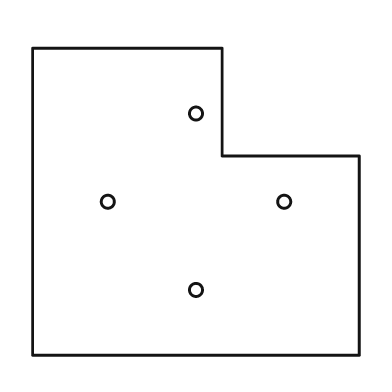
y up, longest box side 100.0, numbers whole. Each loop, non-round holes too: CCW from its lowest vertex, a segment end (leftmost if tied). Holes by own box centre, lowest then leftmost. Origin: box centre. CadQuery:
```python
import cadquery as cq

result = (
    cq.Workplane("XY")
    .moveTo(-50.0, -47.0)
    .lineTo(50.0, -47.0)
    .lineTo(50.0, 14.0)
    .lineTo(8.0, 14.0)
    .lineTo(8.0, 47.0)
    .lineTo(-50.0, 47.0)
    .close()
    .moveTo(0.0, -27.0)
    .circle(2.0)
    .moveTo(-27.0, 0.0)
    .circle(2.0)
    .moveTo(27.0, 0.0)
    .circle(2.0)
    .moveTo(0.0, 27.0)
    .circle(2.0)
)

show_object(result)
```